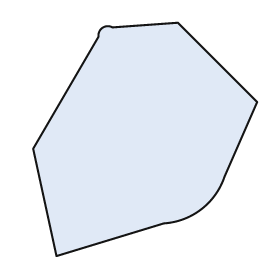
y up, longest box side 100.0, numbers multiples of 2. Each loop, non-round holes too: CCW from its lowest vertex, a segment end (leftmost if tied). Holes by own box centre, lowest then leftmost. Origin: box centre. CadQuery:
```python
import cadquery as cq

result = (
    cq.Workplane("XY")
    .moveTo(-38.0, -50.0)
    .lineTo(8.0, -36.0)
    .threePointArc((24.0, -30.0), (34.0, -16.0))
    .lineTo(48.0, 16.0)
    .lineTo(14.0, 50.0)
    .lineTo(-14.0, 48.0)
    .threePointArc((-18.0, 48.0), (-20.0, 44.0))
    .lineTo(-48.0, -4.0)
    .close()
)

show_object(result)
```